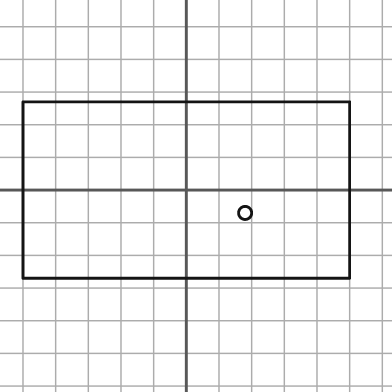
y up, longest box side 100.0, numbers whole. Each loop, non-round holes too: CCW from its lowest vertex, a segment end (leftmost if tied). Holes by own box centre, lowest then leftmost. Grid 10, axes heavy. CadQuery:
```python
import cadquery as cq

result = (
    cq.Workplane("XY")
    .moveTo(-50.0, -27.0)
    .lineTo(50.0, -27.0)
    .lineTo(50.0, 27.0)
    .lineTo(-50.0, 27.0)
    .close()
    .moveTo(18.0, -7.0)
    .circle(2.0)
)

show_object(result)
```